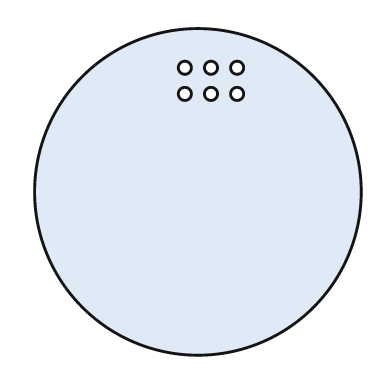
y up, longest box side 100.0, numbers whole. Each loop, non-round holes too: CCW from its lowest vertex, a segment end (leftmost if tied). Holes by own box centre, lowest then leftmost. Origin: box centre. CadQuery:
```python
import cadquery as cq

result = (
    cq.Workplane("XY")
    .moveTo(0.0, 0.0)
    .circle(50.0)
    .moveTo(-4.0, 30.0)
    .circle(2.0)
    .moveTo(4.0, 30.0)
    .circle(2.0)
    .moveTo(12.0, 30.0)
    .circle(2.0)
    .moveTo(-4.0, 38.0)
    .circle(2.0)
    .moveTo(4.0, 38.0)
    .circle(2.0)
    .moveTo(12.0, 38.0)
    .circle(2.0)
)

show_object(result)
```